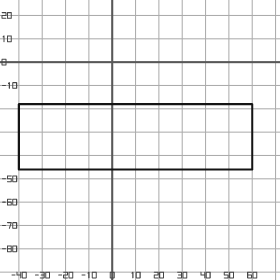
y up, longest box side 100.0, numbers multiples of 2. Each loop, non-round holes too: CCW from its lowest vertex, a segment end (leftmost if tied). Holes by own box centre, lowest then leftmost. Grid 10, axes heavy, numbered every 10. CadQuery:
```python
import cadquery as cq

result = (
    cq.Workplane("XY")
    .moveTo(-40.0, -46.0)
    .lineTo(60.0, -46.0)
    .lineTo(60.0, -18.0)
    .lineTo(-40.0, -18.0)
    .close()
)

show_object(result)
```